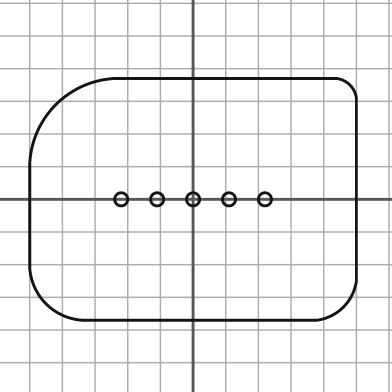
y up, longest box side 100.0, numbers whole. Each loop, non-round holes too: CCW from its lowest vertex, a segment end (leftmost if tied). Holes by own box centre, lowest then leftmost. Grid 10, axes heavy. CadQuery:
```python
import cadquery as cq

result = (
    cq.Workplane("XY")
    .moveTo(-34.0, -37.0)
    .lineTo(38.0, -37.0)
    .threePointArc((46.0, -33.0), (50.0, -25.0))
    .lineTo(50.0, 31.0)
    .threePointArc((48.0, 35.0), (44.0, 37.0))
    .lineTo(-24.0, 37.0)
    .threePointArc((-42.0, 29.0), (-50.0, 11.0))
    .lineTo(-50.0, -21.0)
    .threePointArc((-45.0, -32.0), (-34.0, -37.0))
    .close()
    .moveTo(-22.0, 0.0)
    .circle(2.0)
    .moveTo(-11.0, 0.0)
    .circle(2.0)
    .moveTo(0.0, 0.0)
    .circle(2.0)
    .moveTo(11.0, 0.0)
    .circle(2.0)
    .moveTo(22.0, 0.0)
    .circle(2.0)
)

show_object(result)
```